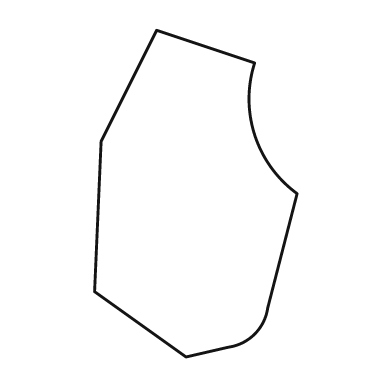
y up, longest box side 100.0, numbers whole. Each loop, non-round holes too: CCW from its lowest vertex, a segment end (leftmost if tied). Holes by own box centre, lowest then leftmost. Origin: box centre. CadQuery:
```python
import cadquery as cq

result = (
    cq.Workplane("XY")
    .moveTo(-3.0, -50.0)
    .lineTo(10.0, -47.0)
    .threePointArc((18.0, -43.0), (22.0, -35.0))
    .lineTo(31.0, 0.0)
    .threePointArc((18.0, 18.0), (18.0, 40.0))
    .lineTo(-12.0, 50.0)
    .lineTo(-29.0, 16.0)
    .lineTo(-31.0, -30.0)
    .close()
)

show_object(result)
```